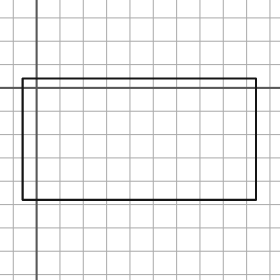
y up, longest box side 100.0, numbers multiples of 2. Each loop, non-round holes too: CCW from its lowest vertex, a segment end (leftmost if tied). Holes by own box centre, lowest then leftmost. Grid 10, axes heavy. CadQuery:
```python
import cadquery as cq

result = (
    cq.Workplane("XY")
    .moveTo(-6.0, -48.0)
    .lineTo(94.0, -48.0)
    .lineTo(94.0, 4.0)
    .lineTo(-6.0, 4.0)
    .close()
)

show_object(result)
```